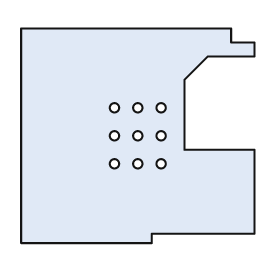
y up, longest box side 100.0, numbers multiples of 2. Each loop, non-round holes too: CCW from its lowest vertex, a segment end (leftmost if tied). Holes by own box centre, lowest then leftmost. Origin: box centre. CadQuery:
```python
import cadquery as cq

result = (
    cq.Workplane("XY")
    .moveTo(-50.0, -46.0)
    .lineTo(6.0, -46.0)
    .lineTo(6.0, -42.0)
    .lineTo(50.0, -42.0)
    .lineTo(50.0, -6.0)
    .lineTo(20.0, -6.0)
    .lineTo(20.0, 24.0)
    .lineTo(30.0, 34.0)
    .lineTo(50.0, 34.0)
    .lineTo(50.0, 40.0)
    .lineTo(40.0, 40.0)
    .lineTo(40.0, 46.0)
    .lineTo(-50.0, 46.0)
    .close()
    .moveTo(-10.0, -12.0)
    .circle(2.0)
    .moveTo(0.0, -12.0)
    .circle(2.0)
    .moveTo(10.0, -12.0)
    .circle(2.0)
    .moveTo(-10.0, 0.0)
    .circle(2.0)
    .moveTo(0.0, 0.0)
    .circle(2.0)
    .moveTo(10.0, 0.0)
    .circle(2.0)
    .moveTo(-10.0, 12.0)
    .circle(2.0)
    .moveTo(0.0, 12.0)
    .circle(2.0)
    .moveTo(10.0, 12.0)
    .circle(2.0)
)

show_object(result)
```